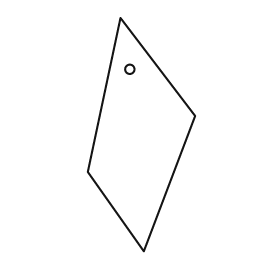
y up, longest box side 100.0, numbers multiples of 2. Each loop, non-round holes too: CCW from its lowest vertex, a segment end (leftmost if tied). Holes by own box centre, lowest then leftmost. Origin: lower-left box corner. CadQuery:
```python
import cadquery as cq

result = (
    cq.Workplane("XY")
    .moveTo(24.0, 0.0)
    .lineTo(46.0, 58.0)
    .lineTo(14.0, 100.0)
    .lineTo(0.0, 34.0)
    .close()
    .moveTo(18.0, 78.0)
    .circle(2.0)
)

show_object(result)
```